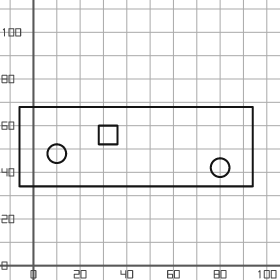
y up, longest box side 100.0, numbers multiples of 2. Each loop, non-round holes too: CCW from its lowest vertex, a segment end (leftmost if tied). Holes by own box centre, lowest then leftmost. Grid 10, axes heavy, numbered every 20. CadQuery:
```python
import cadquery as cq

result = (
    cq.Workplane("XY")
    .moveTo(-6.0, 34.0)
    .lineTo(94.0, 34.0)
    .lineTo(94.0, 68.0)
    .lineTo(-6.0, 68.0)
    .close()
    .moveTo(80.0, 42.0)
    .circle(4.0)
    .moveTo(10.0, 48.0)
    .circle(4.0)
    .moveTo(28.0, 52.0)
    .lineTo(36.0, 52.0)
    .lineTo(36.0, 60.0)
    .lineTo(28.0, 60.0)
    .close()
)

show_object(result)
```